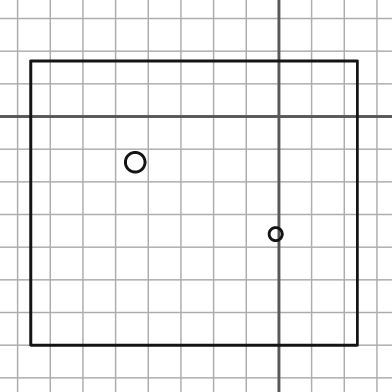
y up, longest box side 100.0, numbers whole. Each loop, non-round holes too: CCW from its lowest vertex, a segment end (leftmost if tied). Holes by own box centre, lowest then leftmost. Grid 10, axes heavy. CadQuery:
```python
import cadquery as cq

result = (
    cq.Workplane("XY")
    .moveTo(-76.0, -70.0)
    .lineTo(24.0, -70.0)
    .lineTo(24.0, 17.0)
    .lineTo(-76.0, 17.0)
    .close()
    .moveTo(-1.0, -36.0)
    .circle(2.0)
    .moveTo(-44.0, -14.0)
    .circle(3.0)
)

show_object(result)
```